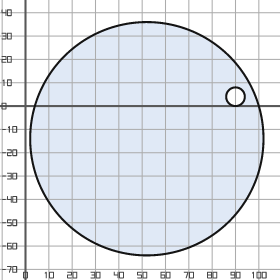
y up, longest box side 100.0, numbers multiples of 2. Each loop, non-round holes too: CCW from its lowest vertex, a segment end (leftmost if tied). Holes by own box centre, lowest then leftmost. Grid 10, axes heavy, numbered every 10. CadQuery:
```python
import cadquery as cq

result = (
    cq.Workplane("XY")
    .moveTo(52.0, -14.0)
    .circle(50.0)
    .moveTo(90.0, 4.0)
    .circle(4.0)
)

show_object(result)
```